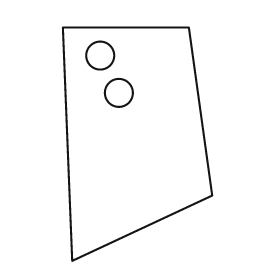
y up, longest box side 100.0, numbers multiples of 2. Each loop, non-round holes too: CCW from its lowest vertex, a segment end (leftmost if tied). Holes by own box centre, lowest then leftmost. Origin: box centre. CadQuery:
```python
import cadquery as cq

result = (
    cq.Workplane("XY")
    .moveTo(-28.0, -50.0)
    .lineTo(32.0, -22.0)
    .lineTo(22.0, 50.0)
    .lineTo(-32.0, 50.0)
    .close()
    .moveTo(-8.0, 22.0)
    .circle(6.0)
    .moveTo(-16.0, 38.0)
    .circle(6.0)
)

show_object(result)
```